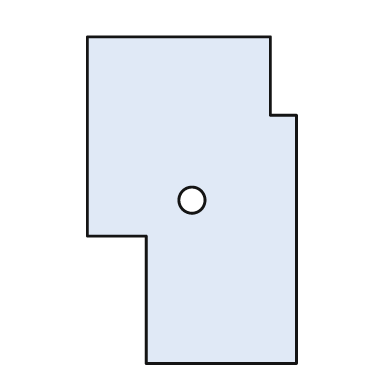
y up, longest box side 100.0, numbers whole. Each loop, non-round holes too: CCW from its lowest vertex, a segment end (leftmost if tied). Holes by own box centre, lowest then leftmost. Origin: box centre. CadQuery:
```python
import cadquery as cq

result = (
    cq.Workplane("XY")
    .moveTo(-14.0, -50.0)
    .lineTo(32.0, -50.0)
    .lineTo(32.0, 26.0)
    .lineTo(24.0, 26.0)
    .lineTo(24.0, 50.0)
    .lineTo(-32.0, 50.0)
    .lineTo(-32.0, -11.0)
    .lineTo(-14.0, -11.0)
    .close()
    .moveTo(0.0, 0.0)
    .circle(4.0)
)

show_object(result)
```